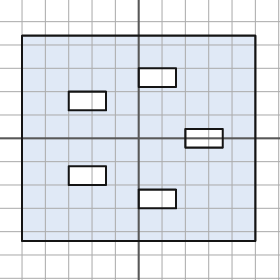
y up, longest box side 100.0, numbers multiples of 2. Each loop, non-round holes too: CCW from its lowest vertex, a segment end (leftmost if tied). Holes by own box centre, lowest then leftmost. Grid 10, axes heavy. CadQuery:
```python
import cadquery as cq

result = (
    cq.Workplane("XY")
    .moveTo(-50.0, -44.0)
    .lineTo(50.0, -44.0)
    .lineTo(50.0, 44.0)
    .lineTo(-50.0, 44.0)
    .close()
    .moveTo(0.0, -30.0)
    .lineTo(16.0, -30.0)
    .lineTo(16.0, -22.0)
    .lineTo(0.0, -22.0)
    .close()
    .moveTo(-30.0, -20.0)
    .lineTo(-14.0, -20.0)
    .lineTo(-14.0, -12.0)
    .lineTo(-30.0, -12.0)
    .close()
    .moveTo(20.0, -4.0)
    .lineTo(36.0, -4.0)
    .lineTo(36.0, 4.0)
    .lineTo(20.0, 4.0)
    .close()
    .moveTo(-30.0, 12.0)
    .lineTo(-14.0, 12.0)
    .lineTo(-14.0, 20.0)
    .lineTo(-30.0, 20.0)
    .close()
    .moveTo(0.0, 22.0)
    .lineTo(16.0, 22.0)
    .lineTo(16.0, 30.0)
    .lineTo(0.0, 30.0)
    .close()
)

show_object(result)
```